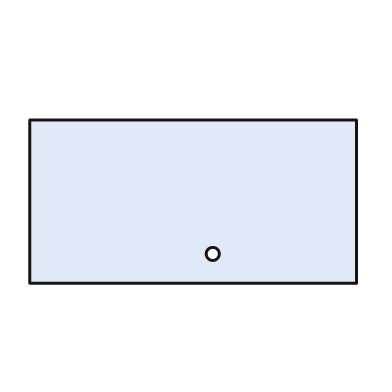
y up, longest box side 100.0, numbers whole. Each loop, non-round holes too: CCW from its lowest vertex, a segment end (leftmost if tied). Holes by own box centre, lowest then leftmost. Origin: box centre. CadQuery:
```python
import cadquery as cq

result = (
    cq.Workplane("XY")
    .moveTo(-50.0, -25.0)
    .lineTo(50.0, -25.0)
    .lineTo(50.0, 25.0)
    .lineTo(-50.0, 25.0)
    .close()
    .moveTo(6.0, -16.0)
    .circle(2.0)
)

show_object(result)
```